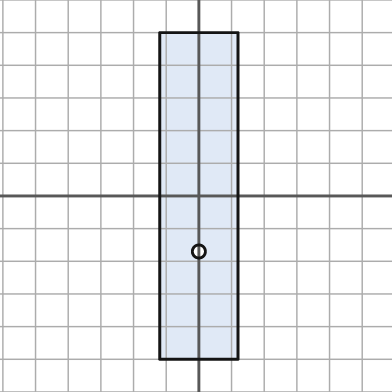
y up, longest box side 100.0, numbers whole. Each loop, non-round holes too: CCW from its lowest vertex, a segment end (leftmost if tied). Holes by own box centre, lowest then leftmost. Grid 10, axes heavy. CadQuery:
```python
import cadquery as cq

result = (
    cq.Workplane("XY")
    .moveTo(-12.0, -50.0)
    .lineTo(12.0, -50.0)
    .lineTo(12.0, 50.0)
    .lineTo(-12.0, 50.0)
    .close()
    .moveTo(0.0, -17.0)
    .circle(2.0)
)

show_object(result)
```